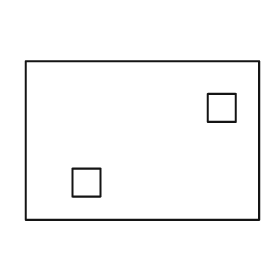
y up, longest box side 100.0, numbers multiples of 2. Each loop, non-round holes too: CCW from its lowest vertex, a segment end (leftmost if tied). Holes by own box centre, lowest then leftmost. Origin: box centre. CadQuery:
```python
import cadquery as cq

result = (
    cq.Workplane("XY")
    .moveTo(-50.0, -34.0)
    .lineTo(50.0, -34.0)
    .lineTo(50.0, 34.0)
    .lineTo(-50.0, 34.0)
    .close()
    .moveTo(-30.0, -24.0)
    .lineTo(-18.0, -24.0)
    .lineTo(-18.0, -12.0)
    .lineTo(-30.0, -12.0)
    .close()
    .moveTo(28.0, 8.0)
    .lineTo(40.0, 8.0)
    .lineTo(40.0, 20.0)
    .lineTo(28.0, 20.0)
    .close()
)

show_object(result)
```